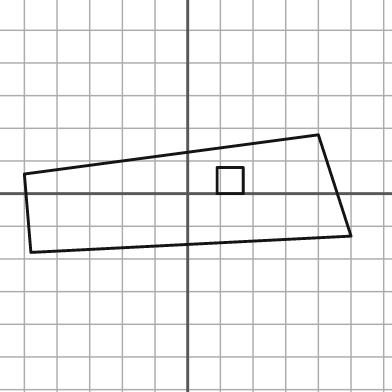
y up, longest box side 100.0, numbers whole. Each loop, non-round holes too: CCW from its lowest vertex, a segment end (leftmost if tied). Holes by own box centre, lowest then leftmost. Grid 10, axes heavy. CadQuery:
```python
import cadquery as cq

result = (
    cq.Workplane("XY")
    .moveTo(-48.0, -18.0)
    .lineTo(50.0, -13.0)
    .lineTo(40.0, 18.0)
    .lineTo(-50.0, 6.0)
    .close()
    .moveTo(9.0, 0.0)
    .lineTo(17.0, 0.0)
    .lineTo(17.0, 8.0)
    .lineTo(9.0, 8.0)
    .close()
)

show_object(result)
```